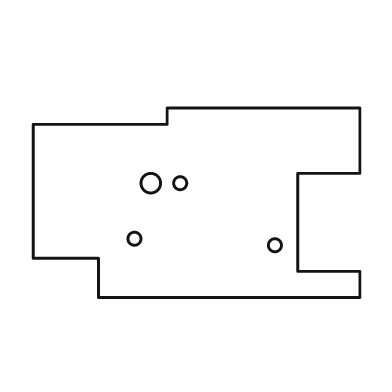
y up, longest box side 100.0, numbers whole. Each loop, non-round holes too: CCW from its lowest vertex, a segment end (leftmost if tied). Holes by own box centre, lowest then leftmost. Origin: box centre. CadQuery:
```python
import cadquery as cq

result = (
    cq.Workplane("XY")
    .moveTo(-30.0, -29.0)
    .lineTo(50.0, -29.0)
    .lineTo(50.0, -21.0)
    .lineTo(31.0, -21.0)
    .lineTo(31.0, 9.0)
    .lineTo(50.0, 9.0)
    .lineTo(50.0, 29.0)
    .lineTo(-9.0, 29.0)
    .lineTo(-9.0, 24.0)
    .lineTo(-50.0, 24.0)
    .lineTo(-50.0, -17.0)
    .lineTo(-30.0, -17.0)
    .close()
    .moveTo(24.0, -13.0)
    .circle(2.0)
    .moveTo(-19.0, -11.0)
    .circle(2.0)
    .moveTo(-14.0, 6.0)
    .circle(3.0)
    .moveTo(-5.0, 6.0)
    .circle(2.0)
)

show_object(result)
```